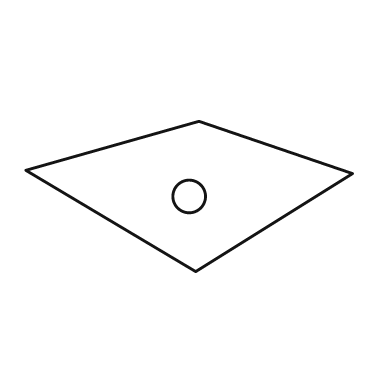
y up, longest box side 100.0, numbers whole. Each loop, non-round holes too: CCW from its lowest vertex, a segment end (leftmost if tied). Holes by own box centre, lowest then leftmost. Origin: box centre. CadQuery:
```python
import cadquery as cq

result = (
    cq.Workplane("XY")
    .moveTo(2.0, -23.0)
    .lineTo(50.0, 7.0)
    .lineTo(3.0, 23.0)
    .lineTo(-50.0, 8.0)
    .close()
    .moveTo(0.0, 0.0)
    .circle(5.0)
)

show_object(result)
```